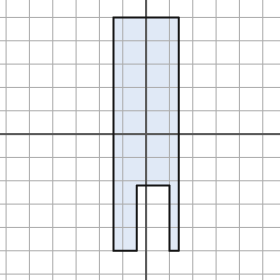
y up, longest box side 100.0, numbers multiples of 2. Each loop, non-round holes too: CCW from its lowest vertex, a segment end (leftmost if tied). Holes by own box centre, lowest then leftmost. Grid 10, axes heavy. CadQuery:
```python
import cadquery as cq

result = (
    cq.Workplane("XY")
    .moveTo(-14.0, -50.0)
    .lineTo(-4.0, -50.0)
    .lineTo(-4.0, -22.0)
    .lineTo(10.0, -22.0)
    .lineTo(10.0, -50.0)
    .lineTo(14.0, -50.0)
    .lineTo(14.0, 50.0)
    .lineTo(-14.0, 50.0)
    .close()
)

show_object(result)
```